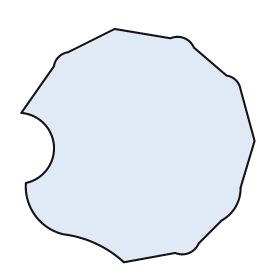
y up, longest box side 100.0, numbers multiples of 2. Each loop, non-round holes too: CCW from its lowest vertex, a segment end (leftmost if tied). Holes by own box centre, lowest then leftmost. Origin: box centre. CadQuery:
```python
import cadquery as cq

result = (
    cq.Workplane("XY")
    .moveTo(-6.0, -50.0)
    .lineTo(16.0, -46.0)
    .threePointArc((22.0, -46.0), (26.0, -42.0))
    .lineTo(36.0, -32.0)
    .threePointArc((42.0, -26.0), (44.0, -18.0))
    .lineTo(50.0, 2.0)
    .lineTo(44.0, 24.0)
    .threePointArc((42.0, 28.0), (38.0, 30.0))
    .lineTo(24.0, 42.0)
    .threePointArc((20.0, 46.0), (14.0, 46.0))
    .lineTo(-10.0, 50.0)
    .lineTo(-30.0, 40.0)
    .threePointArc((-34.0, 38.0), (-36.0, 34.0))
    .lineTo(-50.0, 14.0)
    .threePointArc((-36.0, 0.0), (-48.0, -16.0))
    .threePointArc((-44.0, -30.0), (-32.0, -38.0))
    .threePointArc((-18.0, -42.0), (-6.0, -50.0))
    .close()
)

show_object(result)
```